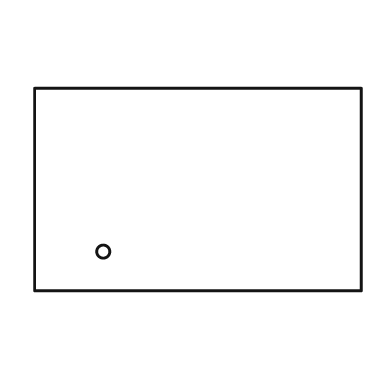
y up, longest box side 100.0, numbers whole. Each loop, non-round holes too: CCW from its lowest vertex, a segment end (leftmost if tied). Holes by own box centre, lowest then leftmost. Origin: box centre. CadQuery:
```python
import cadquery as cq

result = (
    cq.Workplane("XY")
    .moveTo(-50.0, -31.0)
    .lineTo(50.0, -31.0)
    .lineTo(50.0, 31.0)
    .lineTo(-50.0, 31.0)
    .close()
    .moveTo(-29.0, -19.0)
    .circle(2.0)
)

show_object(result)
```